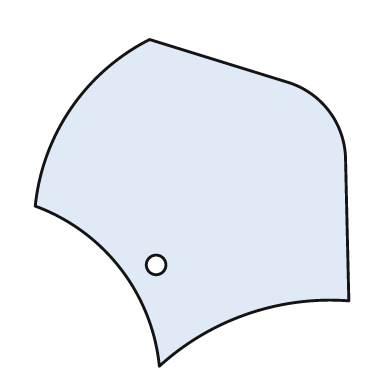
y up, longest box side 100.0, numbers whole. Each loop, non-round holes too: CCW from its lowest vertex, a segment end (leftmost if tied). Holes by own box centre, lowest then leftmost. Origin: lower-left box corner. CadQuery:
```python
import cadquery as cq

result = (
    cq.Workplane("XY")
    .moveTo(38.0, 0.0)
    .threePointArc((65.0, 16.0), (96.0, 20.0))
    .lineTo(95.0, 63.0)
    .threePointArc((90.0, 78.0), (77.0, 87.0))
    .lineTo(35.0, 100.0)
    .threePointArc((11.0, 79.0), (0.0, 49.0))
    .threePointArc((26.0, 30.0), (38.0, 0.0))
    .close()
    .moveTo(37.0, 31.0)
    .circle(3.0)
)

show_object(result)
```